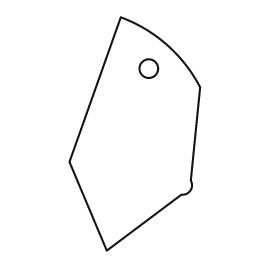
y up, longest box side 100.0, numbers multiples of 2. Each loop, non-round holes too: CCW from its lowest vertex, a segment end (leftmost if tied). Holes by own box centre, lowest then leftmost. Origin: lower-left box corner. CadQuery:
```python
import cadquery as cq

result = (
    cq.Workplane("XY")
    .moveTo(16.0, 0.0)
    .lineTo(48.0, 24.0)
    .threePointArc((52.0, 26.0), (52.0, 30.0))
    .lineTo(56.0, 70.0)
    .threePointArc((42.0, 88.0), (22.0, 100.0))
    .lineTo(0.0, 38.0)
    .close()
    .moveTo(34.0, 78.0)
    .circle(4.0)
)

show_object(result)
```